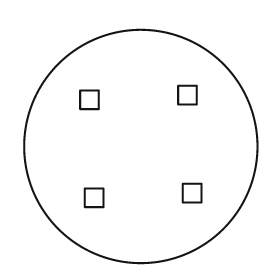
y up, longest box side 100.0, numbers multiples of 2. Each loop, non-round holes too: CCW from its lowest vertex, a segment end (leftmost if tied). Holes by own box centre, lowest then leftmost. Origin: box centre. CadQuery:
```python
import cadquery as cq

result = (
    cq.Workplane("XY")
    .moveTo(0.0, 0.0)
    .circle(50.0)
    .moveTo(-24.0, -26.0)
    .lineTo(-16.0, -26.0)
    .lineTo(-16.0, -18.0)
    .lineTo(-24.0, -18.0)
    .close()
    .moveTo(18.0, -24.0)
    .lineTo(26.0, -24.0)
    .lineTo(26.0, -16.0)
    .lineTo(18.0, -16.0)
    .close()
    .moveTo(-26.0, 16.0)
    .lineTo(-18.0, 16.0)
    .lineTo(-18.0, 24.0)
    .lineTo(-26.0, 24.0)
    .close()
    .moveTo(16.0, 18.0)
    .lineTo(24.0, 18.0)
    .lineTo(24.0, 26.0)
    .lineTo(16.0, 26.0)
    .close()
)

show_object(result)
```